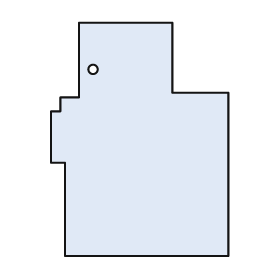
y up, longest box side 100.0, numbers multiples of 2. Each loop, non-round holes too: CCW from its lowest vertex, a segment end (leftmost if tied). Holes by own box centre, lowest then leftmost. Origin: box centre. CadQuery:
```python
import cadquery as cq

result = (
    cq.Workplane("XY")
    .moveTo(-32.0, -50.0)
    .lineTo(38.0, -50.0)
    .lineTo(38.0, 20.0)
    .lineTo(14.0, 20.0)
    .lineTo(14.0, 50.0)
    .lineTo(-26.0, 50.0)
    .lineTo(-26.0, 18.0)
    .lineTo(-34.0, 18.0)
    .lineTo(-34.0, 12.0)
    .lineTo(-38.0, 12.0)
    .lineTo(-38.0, -10.0)
    .lineTo(-32.0, -10.0)
    .close()
    .moveTo(-20.0, 30.0)
    .circle(2.0)
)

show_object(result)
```